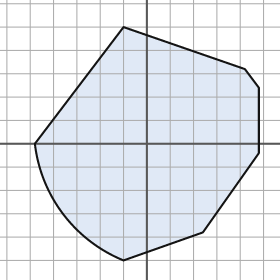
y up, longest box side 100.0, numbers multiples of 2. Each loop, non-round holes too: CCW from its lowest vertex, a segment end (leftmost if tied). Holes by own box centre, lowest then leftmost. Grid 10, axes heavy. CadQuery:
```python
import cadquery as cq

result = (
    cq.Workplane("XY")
    .moveTo(-10.0, -50.0)
    .lineTo(24.0, -38.0)
    .lineTo(48.0, -4.0)
    .lineTo(48.0, 24.0)
    .lineTo(42.0, 32.0)
    .lineTo(-10.0, 50.0)
    .lineTo(-48.0, 0.0)
    .threePointArc((-36.0, -30.0), (-10.0, -50.0))
    .close()
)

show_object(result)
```